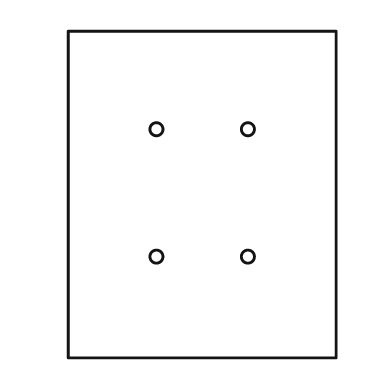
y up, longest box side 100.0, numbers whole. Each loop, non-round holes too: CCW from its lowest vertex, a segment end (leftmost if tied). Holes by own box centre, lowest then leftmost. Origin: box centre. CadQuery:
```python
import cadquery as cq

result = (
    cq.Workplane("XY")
    .moveTo(-41.0, -50.0)
    .lineTo(41.0, -50.0)
    .lineTo(41.0, 50.0)
    .lineTo(-41.0, 50.0)
    .close()
    .moveTo(-14.0, -19.0)
    .circle(2.0)
    .moveTo(14.0, -19.0)
    .circle(2.0)
    .moveTo(-14.0, 20.0)
    .circle(2.0)
    .moveTo(14.0, 20.0)
    .circle(2.0)
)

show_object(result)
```